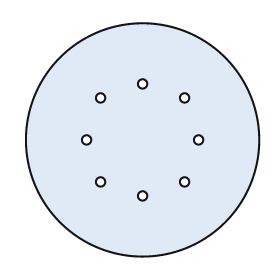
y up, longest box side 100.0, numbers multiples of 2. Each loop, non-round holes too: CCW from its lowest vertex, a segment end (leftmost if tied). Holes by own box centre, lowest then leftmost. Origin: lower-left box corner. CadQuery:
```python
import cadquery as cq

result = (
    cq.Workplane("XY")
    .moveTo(50.0, 50.0)
    .circle(50.0)
    .moveTo(50.0, 26.0)
    .circle(2.0)
    .moveTo(32.0, 32.0)
    .circle(2.0)
    .moveTo(68.0, 32.0)
    .circle(2.0)
    .moveTo(26.0, 50.0)
    .circle(2.0)
    .moveTo(74.0, 50.0)
    .circle(2.0)
    .moveTo(32.0, 68.0)
    .circle(2.0)
    .moveTo(68.0, 68.0)
    .circle(2.0)
    .moveTo(50.0, 74.0)
    .circle(2.0)
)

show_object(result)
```